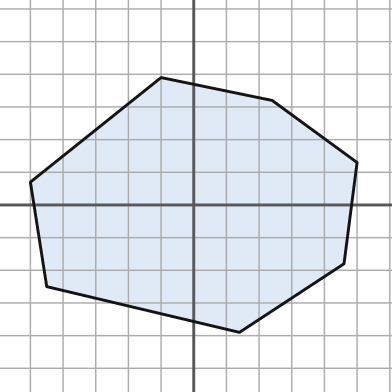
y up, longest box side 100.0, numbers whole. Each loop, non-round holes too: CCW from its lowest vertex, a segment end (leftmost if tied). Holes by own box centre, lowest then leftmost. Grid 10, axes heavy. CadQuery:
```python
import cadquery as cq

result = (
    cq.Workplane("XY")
    .moveTo(14.0, -39.0)
    .lineTo(46.0, -18.0)
    .lineTo(50.0, 13.0)
    .lineTo(24.0, 32.0)
    .lineTo(-10.0, 39.0)
    .lineTo(-50.0, 7.0)
    .lineTo(-45.0, -25.0)
    .close()
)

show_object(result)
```